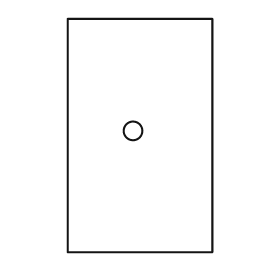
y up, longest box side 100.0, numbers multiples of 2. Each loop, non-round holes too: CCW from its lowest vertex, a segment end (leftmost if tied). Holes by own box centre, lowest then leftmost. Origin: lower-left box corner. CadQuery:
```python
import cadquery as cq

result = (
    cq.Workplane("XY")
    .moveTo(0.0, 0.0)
    .lineTo(62.0, 0.0)
    .lineTo(62.0, 100.0)
    .lineTo(0.0, 100.0)
    .close()
    .moveTo(28.0, 52.0)
    .circle(4.0)
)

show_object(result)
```